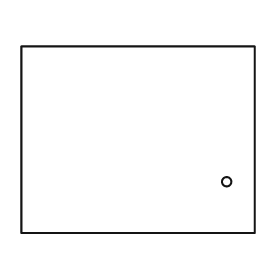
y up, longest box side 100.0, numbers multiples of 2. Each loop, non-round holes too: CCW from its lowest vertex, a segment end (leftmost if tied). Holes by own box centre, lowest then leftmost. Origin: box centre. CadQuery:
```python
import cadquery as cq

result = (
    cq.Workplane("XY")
    .moveTo(-50.0, -40.0)
    .lineTo(50.0, -40.0)
    .lineTo(50.0, 40.0)
    .lineTo(-50.0, 40.0)
    .close()
    .moveTo(38.0, -18.0)
    .circle(2.0)
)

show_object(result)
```